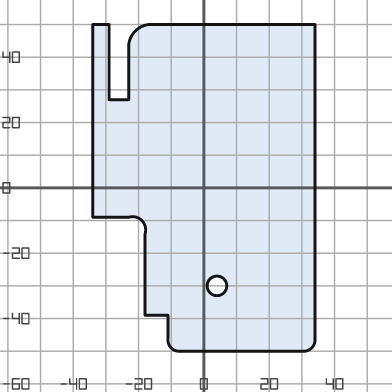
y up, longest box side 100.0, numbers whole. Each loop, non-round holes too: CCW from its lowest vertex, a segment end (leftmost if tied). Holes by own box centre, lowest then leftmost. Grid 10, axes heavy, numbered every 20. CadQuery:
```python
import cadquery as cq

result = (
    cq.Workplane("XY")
    .moveTo(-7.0, -50.0)
    .lineTo(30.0, -50.0)
    .threePointArc((33.0, -49.0), (34.0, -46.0))
    .lineTo(34.0, 50.0)
    .lineTo(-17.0, 50.0)
    .threePointArc((-21.0, 48.0), (-23.0, 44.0))
    .lineTo(-23.0, 27.0)
    .lineTo(-29.0, 27.0)
    .lineTo(-29.0, 50.0)
    .lineTo(-34.0, 50.0)
    .lineTo(-34.0, -9.0)
    .lineTo(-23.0, -9.0)
    .threePointArc((-19.0, -10.0), (-18.0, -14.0))
    .lineTo(-18.0, -39.0)
    .lineTo(-11.0, -39.0)
    .lineTo(-11.0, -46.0)
    .threePointArc((-10.0, -49.0), (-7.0, -50.0))
    .close()
    .moveTo(4.0, -30.0)
    .circle(3.0)
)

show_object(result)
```